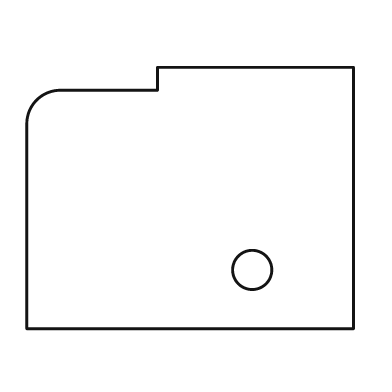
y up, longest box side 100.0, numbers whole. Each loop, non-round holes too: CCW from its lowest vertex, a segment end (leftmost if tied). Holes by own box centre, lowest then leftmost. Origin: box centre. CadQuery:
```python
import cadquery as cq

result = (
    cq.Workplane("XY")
    .moveTo(-50.0, -40.0)
    .lineTo(50.0, -40.0)
    .lineTo(50.0, 40.0)
    .lineTo(-10.0, 40.0)
    .lineTo(-10.0, 33.0)
    .lineTo(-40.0, 33.0)
    .threePointArc((-47.0, 30.0), (-50.0, 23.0))
    .close()
    .moveTo(19.0, -22.0)
    .circle(6.0)
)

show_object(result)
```